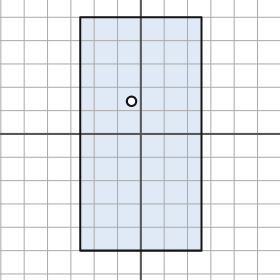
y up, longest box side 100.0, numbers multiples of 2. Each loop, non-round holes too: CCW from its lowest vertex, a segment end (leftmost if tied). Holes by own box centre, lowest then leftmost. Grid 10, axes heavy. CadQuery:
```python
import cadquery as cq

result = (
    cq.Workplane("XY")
    .moveTo(-26.0, -50.0)
    .lineTo(26.0, -50.0)
    .lineTo(26.0, 50.0)
    .lineTo(-26.0, 50.0)
    .close()
    .moveTo(-4.0, 14.0)
    .circle(2.0)
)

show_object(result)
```